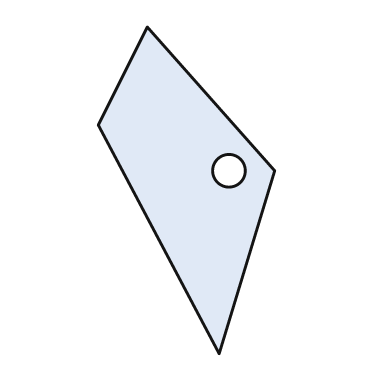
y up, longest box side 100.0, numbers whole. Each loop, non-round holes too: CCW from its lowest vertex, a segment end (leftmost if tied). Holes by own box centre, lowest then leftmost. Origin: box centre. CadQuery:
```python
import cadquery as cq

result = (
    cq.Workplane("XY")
    .moveTo(10.0, -50.0)
    .lineTo(27.0, 6.0)
    .lineTo(-12.0, 50.0)
    .lineTo(-27.0, 20.0)
    .close()
    .moveTo(13.0, 6.0)
    .circle(5.0)
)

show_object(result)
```